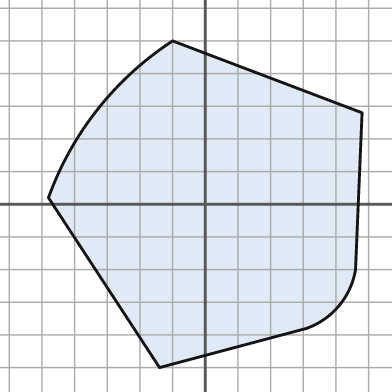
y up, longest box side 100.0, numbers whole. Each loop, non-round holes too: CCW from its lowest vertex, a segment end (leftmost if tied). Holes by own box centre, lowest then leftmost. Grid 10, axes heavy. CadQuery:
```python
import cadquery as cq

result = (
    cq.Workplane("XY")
    .moveTo(-14.0, -50.0)
    .lineTo(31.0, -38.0)
    .threePointArc((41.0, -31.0), (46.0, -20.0))
    .lineTo(48.0, 28.0)
    .lineTo(-10.0, 50.0)
    .threePointArc((-33.0, 29.0), (-48.0, 2.0))
    .close()
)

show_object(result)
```